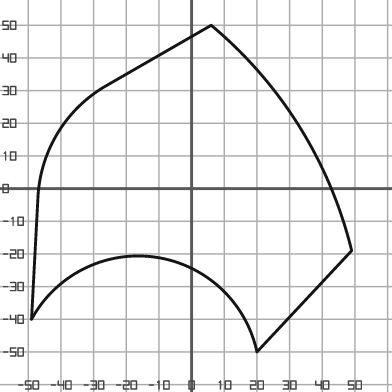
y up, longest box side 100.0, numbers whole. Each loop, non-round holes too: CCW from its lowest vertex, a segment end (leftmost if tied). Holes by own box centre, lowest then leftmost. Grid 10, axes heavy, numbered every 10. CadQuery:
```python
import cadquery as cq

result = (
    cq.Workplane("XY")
    .moveTo(20.0, -50.0)
    .lineTo(49.0, -19.0)
    .threePointArc((33.0, 19.0), (6.0, 50.0))
    .lineTo(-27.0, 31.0)
    .threePointArc((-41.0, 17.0), (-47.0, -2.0))
    .lineTo(-49.0, -40.0)
    .threePointArc((-11.0, -21.0), (20.0, -50.0))
    .close()
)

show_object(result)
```